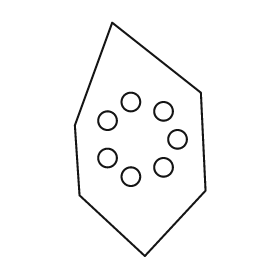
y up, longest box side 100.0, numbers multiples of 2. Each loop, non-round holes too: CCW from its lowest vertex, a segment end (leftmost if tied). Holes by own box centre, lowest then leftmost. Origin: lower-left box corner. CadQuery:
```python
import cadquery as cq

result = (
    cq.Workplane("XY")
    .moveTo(30.0, 0.0)
    .lineTo(56.0, 28.0)
    .lineTo(54.0, 70.0)
    .lineTo(16.0, 100.0)
    .lineTo(0.0, 56.0)
    .lineTo(2.0, 26.0)
    .close()
    .moveTo(24.0, 34.0)
    .circle(4.0)
    .moveTo(38.0, 38.0)
    .circle(4.0)
    .moveTo(14.0, 42.0)
    .circle(4.0)
    .moveTo(44.0, 50.0)
    .circle(4.0)
    .moveTo(14.0, 58.0)
    .circle(4.0)
    .moveTo(38.0, 62.0)
    .circle(4.0)
    .moveTo(24.0, 66.0)
    .circle(4.0)
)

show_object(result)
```